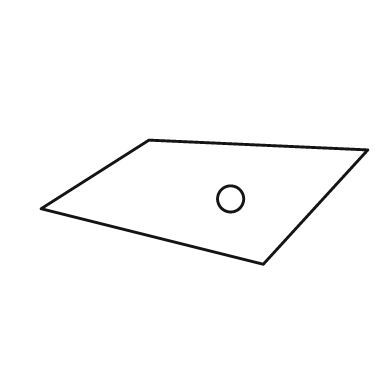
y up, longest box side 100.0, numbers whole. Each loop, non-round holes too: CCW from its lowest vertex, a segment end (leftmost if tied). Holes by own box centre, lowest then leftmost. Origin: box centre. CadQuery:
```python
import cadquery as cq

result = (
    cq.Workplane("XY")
    .moveTo(18.0, -19.0)
    .lineTo(50.0, 16.0)
    .lineTo(-17.0, 19.0)
    .lineTo(-50.0, -2.0)
    .close()
    .moveTo(8.0, 1.0)
    .circle(4.0)
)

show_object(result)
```